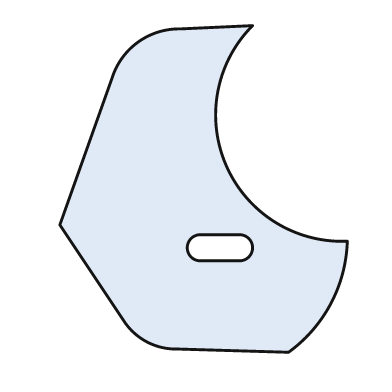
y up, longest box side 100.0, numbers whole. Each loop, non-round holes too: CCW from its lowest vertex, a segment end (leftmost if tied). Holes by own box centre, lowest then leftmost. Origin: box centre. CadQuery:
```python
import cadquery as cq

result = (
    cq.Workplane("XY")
    .moveTo(26.0, -50.0)
    .threePointArc((39.0, -35.0), (44.0, -16.0))
    .threePointArc((7.0, 7.0), (15.0, 50.0))
    .lineTo(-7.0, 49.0)
    .threePointArc((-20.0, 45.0), (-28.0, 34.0))
    .lineTo(-44.0, -11.0)
    .lineTo(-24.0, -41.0)
    .threePointArc((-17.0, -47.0), (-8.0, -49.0))
    .close()
    .moveTo(-1.0, -22.0)
    .lineTo(11.0, -22.0)
    .threePointArc((15.0, -18.0), (11.0, -14.0))
    .lineTo(-1.0, -14.0)
    .threePointArc((-5.0, -18.0), (-1.0, -22.0))
    .close()
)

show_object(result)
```